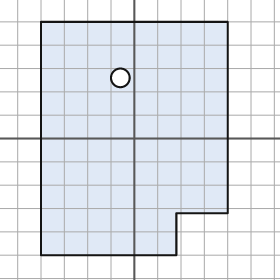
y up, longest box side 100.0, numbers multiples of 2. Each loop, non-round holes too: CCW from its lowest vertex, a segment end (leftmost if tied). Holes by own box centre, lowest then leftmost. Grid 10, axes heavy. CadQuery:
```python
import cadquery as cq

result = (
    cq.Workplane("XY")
    .moveTo(-40.0, -50.0)
    .lineTo(18.0, -50.0)
    .lineTo(18.0, -32.0)
    .lineTo(40.0, -32.0)
    .lineTo(40.0, 50.0)
    .lineTo(-40.0, 50.0)
    .close()
    .moveTo(-6.0, 26.0)
    .circle(4.0)
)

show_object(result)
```